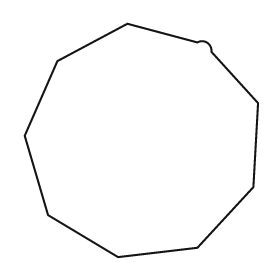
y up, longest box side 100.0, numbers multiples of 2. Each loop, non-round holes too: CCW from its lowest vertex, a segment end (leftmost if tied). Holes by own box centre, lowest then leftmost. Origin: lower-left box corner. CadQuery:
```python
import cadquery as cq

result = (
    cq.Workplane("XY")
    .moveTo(40.0, 0.0)
    .lineTo(74.0, 4.0)
    .lineTo(98.0, 30.0)
    .lineTo(100.0, 66.0)
    .lineTo(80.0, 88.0)
    .threePointArc((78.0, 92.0), (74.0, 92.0))
    .lineTo(44.0, 100.0)
    .lineTo(14.0, 84.0)
    .lineTo(0.0, 52.0)
    .lineTo(10.0, 18.0)
    .close()
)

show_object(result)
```